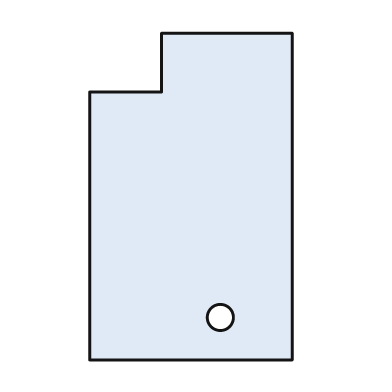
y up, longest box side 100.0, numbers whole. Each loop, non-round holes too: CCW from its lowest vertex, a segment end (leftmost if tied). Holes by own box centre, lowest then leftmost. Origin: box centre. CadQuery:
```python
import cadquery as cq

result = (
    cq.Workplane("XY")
    .moveTo(-31.0, -50.0)
    .lineTo(31.0, -50.0)
    .lineTo(31.0, 50.0)
    .lineTo(-9.0, 50.0)
    .lineTo(-9.0, 32.0)
    .lineTo(-31.0, 32.0)
    .close()
    .moveTo(9.0, -37.0)
    .circle(4.0)
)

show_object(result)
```